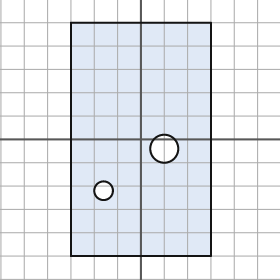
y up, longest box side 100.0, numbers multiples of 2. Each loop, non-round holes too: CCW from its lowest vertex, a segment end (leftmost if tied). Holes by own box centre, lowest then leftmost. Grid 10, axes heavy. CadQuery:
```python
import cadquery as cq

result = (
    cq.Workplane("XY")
    .moveTo(-30.0, -50.0)
    .lineTo(30.0, -50.0)
    .lineTo(30.0, 50.0)
    .lineTo(-30.0, 50.0)
    .close()
    .moveTo(-16.0, -22.0)
    .circle(4.0)
    .moveTo(10.0, -4.0)
    .circle(6.0)
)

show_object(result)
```